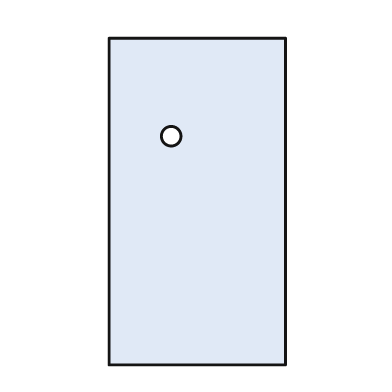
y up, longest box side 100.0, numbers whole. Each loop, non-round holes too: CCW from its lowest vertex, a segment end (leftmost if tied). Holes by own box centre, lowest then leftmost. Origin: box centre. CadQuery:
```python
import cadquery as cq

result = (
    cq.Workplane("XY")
    .moveTo(-27.0, -50.0)
    .lineTo(27.0, -50.0)
    .lineTo(27.0, 50.0)
    .lineTo(-27.0, 50.0)
    .close()
    .moveTo(-8.0, 20.0)
    .circle(3.0)
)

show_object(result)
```